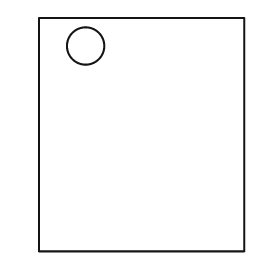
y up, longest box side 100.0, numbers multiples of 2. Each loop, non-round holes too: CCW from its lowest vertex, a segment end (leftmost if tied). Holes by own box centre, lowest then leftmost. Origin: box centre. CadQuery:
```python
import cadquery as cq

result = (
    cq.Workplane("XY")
    .moveTo(-44.0, -50.0)
    .lineTo(44.0, -50.0)
    .lineTo(44.0, 50.0)
    .lineTo(-44.0, 50.0)
    .close()
    .moveTo(-24.0, 38.0)
    .circle(8.0)
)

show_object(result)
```